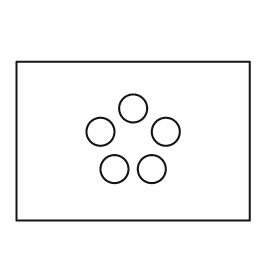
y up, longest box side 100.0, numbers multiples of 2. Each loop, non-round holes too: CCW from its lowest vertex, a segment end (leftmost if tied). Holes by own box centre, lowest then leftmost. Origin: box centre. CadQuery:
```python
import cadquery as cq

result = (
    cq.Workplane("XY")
    .moveTo(-50.0, -34.0)
    .lineTo(50.0, -34.0)
    .lineTo(50.0, 34.0)
    .lineTo(-50.0, 34.0)
    .close()
    .moveTo(-8.0, -12.0)
    .circle(6.0)
    .moveTo(8.0, -12.0)
    .circle(6.0)
    .moveTo(-14.0, 4.0)
    .circle(6.0)
    .moveTo(14.0, 4.0)
    .circle(6.0)
    .moveTo(0.0, 14.0)
    .circle(6.0)
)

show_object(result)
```